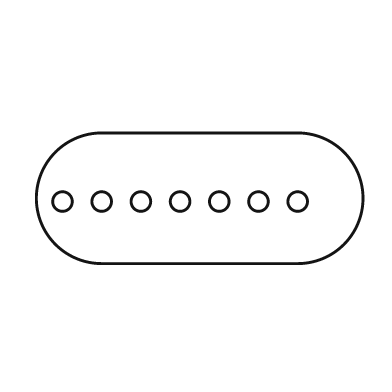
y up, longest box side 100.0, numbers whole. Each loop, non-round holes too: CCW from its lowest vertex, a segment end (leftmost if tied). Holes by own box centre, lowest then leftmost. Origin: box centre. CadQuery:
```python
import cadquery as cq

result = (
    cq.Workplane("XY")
    .moveTo(-30.0, -20.0)
    .lineTo(30.0, -20.0)
    .threePointArc((50.0, 0.0), (30.0, 20.0))
    .lineTo(-30.0, 20.0)
    .threePointArc((-50.0, 0.0), (-30.0, -20.0))
    .close()
    .moveTo(-42.0, -1.0)
    .circle(3.0)
    .moveTo(-30.0, -1.0)
    .circle(3.0)
    .moveTo(-18.0, -1.0)
    .circle(3.0)
    .moveTo(-6.0, -1.0)
    .circle(3.0)
    .moveTo(6.0, -1.0)
    .circle(3.0)
    .moveTo(18.0, -1.0)
    .circle(3.0)
    .moveTo(30.0, -1.0)
    .circle(3.0)
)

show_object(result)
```